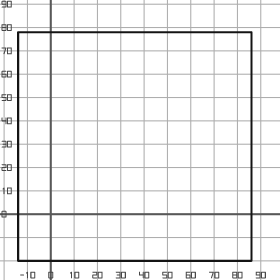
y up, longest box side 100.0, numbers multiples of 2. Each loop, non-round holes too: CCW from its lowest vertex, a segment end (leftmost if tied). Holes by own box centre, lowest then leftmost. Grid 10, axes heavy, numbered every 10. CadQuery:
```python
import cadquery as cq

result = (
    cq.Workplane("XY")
    .moveTo(-14.0, -20.0)
    .lineTo(86.0, -20.0)
    .lineTo(86.0, 78.0)
    .lineTo(-14.0, 78.0)
    .close()
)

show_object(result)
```